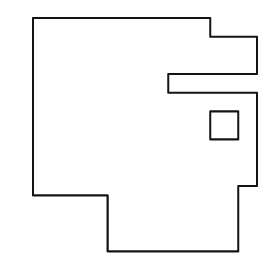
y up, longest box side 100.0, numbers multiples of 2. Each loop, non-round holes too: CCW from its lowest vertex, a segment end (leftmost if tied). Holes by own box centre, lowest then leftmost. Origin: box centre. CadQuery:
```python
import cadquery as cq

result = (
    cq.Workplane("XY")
    .moveTo(-16.0, -50.0)
    .lineTo(40.0, -50.0)
    .lineTo(40.0, -22.0)
    .lineTo(48.0, -22.0)
    .lineTo(48.0, 18.0)
    .lineTo(10.0, 18.0)
    .lineTo(10.0, 26.0)
    .lineTo(48.0, 26.0)
    .lineTo(48.0, 42.0)
    .lineTo(28.0, 42.0)
    .lineTo(28.0, 50.0)
    .lineTo(-48.0, 50.0)
    .lineTo(-48.0, -26.0)
    .lineTo(-16.0, -26.0)
    .close()
    .moveTo(28.0, -2.0)
    .lineTo(40.0, -2.0)
    .lineTo(40.0, 10.0)
    .lineTo(28.0, 10.0)
    .close()
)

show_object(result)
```